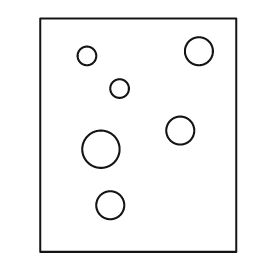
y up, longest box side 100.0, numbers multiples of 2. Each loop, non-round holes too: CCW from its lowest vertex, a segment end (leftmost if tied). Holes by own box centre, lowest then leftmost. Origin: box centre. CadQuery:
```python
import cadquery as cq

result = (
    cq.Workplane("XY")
    .moveTo(-42.0, -50.0)
    .lineTo(42.0, -50.0)
    .lineTo(42.0, 50.0)
    .lineTo(-42.0, 50.0)
    .close()
    .moveTo(-12.0, -30.0)
    .circle(6.0)
    .moveTo(-16.0, -6.0)
    .circle(8.0)
    .moveTo(18.0, 2.0)
    .circle(6.0)
    .moveTo(-8.0, 20.0)
    .circle(4.0)
    .moveTo(-22.0, 34.0)
    .circle(4.0)
    .moveTo(26.0, 36.0)
    .circle(6.0)
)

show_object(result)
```